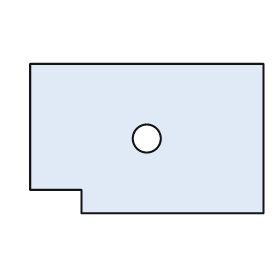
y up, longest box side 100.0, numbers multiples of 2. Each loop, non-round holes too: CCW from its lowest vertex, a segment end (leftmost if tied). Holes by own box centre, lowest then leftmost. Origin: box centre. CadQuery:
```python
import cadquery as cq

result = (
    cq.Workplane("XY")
    .moveTo(-28.0, -32.0)
    .lineTo(50.0, -32.0)
    .lineTo(50.0, 32.0)
    .lineTo(-50.0, 32.0)
    .lineTo(-50.0, -22.0)
    .lineTo(-28.0, -22.0)
    .close()
    .moveTo(0.0, 0.0)
    .circle(6.0)
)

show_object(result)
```